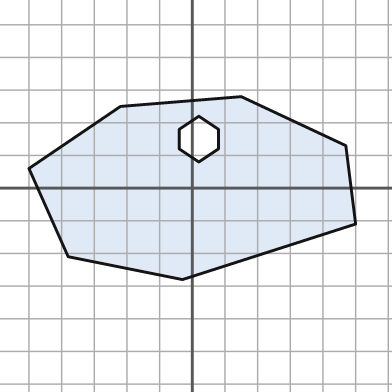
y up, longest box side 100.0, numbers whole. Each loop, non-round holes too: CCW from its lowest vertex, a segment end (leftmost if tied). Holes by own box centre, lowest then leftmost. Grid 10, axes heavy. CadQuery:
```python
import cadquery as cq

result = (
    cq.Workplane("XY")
    .moveTo(-3.0, -28.0)
    .lineTo(50.0, -11.0)
    .lineTo(47.0, 13.0)
    .lineTo(15.0, 28.0)
    .lineTo(-22.0, 25.0)
    .lineTo(-50.0, 6.0)
    .lineTo(-38.0, -21.0)
    .close()
    .moveTo(2.0, 8.0)
    .lineTo(8.0, 12.0)
    .lineTo(8.0, 18.0)
    .lineTo(2.0, 22.0)
    .lineTo(-4.0, 18.0)
    .lineTo(-4.0, 12.0)
    .close()
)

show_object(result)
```